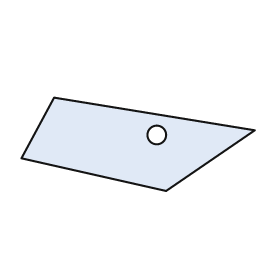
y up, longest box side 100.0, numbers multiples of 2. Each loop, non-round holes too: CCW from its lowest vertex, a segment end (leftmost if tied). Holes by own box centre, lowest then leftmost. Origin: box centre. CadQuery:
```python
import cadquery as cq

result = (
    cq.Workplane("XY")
    .moveTo(12.0, -20.0)
    .lineTo(50.0, 6.0)
    .lineTo(-36.0, 20.0)
    .lineTo(-50.0, -6.0)
    .close()
    .moveTo(8.0, 4.0)
    .circle(4.0)
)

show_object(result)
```